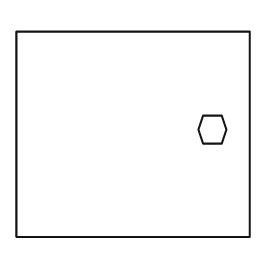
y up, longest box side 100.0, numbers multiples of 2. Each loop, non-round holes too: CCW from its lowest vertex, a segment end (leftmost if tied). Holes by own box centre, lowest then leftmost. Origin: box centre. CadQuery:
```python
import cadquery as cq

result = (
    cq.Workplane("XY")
    .moveTo(-50.0, -44.0)
    .lineTo(50.0, -44.0)
    .lineTo(50.0, 44.0)
    .lineTo(-50.0, 44.0)
    .close()
    .moveTo(30.0, -4.0)
    .lineTo(38.0, -4.0)
    .lineTo(40.0, 2.0)
    .lineTo(38.0, 8.0)
    .lineTo(30.0, 8.0)
    .lineTo(28.0, 2.0)
    .close()
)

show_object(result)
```